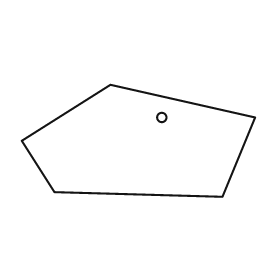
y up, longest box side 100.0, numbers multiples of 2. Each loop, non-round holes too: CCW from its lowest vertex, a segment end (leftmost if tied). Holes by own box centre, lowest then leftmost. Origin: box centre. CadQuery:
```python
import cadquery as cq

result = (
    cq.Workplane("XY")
    .moveTo(36.0, -24.0)
    .lineTo(50.0, 10.0)
    .lineTo(-12.0, 24.0)
    .lineTo(-50.0, 0.0)
    .lineTo(-36.0, -22.0)
    .close()
    .moveTo(10.0, 10.0)
    .circle(2.0)
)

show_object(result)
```